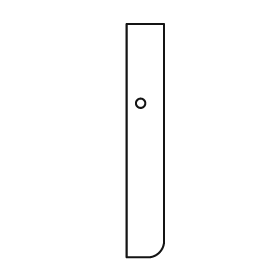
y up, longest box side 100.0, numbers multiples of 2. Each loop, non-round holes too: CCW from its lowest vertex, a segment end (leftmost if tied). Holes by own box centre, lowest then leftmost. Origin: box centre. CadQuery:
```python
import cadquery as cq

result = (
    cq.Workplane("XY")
    .moveTo(-8.0, -50.0)
    .lineTo(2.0, -50.0)
    .threePointArc((6.0, -48.0), (8.0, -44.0))
    .lineTo(8.0, 50.0)
    .lineTo(-8.0, 50.0)
    .close()
    .moveTo(-2.0, 16.0)
    .circle(2.0)
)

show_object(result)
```